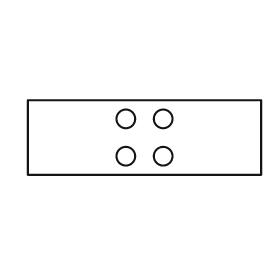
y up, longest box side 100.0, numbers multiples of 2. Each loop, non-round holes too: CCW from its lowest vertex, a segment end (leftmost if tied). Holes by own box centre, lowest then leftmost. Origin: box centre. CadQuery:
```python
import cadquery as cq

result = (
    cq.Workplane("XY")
    .moveTo(-50.0, -16.0)
    .lineTo(50.0, -16.0)
    .lineTo(50.0, 16.0)
    .lineTo(-50.0, 16.0)
    .close()
    .moveTo(-8.0, -8.0)
    .circle(4.0)
    .moveTo(8.0, -8.0)
    .circle(4.0)
    .moveTo(-8.0, 8.0)
    .circle(4.0)
    .moveTo(8.0, 8.0)
    .circle(4.0)
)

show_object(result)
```